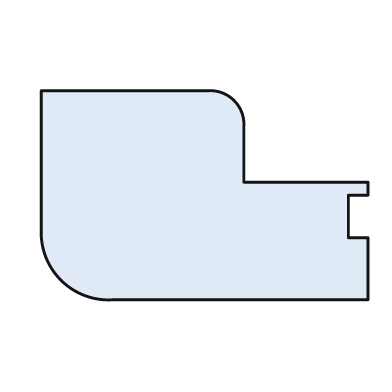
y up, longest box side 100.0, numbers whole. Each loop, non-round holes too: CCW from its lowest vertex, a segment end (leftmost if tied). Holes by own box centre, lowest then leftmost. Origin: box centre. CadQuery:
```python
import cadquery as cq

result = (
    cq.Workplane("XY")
    .moveTo(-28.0, -32.0)
    .lineTo(50.0, -32.0)
    .lineTo(50.0, -13.0)
    .lineTo(44.0, -13.0)
    .lineTo(44.0, 0.0)
    .lineTo(50.0, 0.0)
    .lineTo(50.0, 4.0)
    .lineTo(12.0, 4.0)
    .lineTo(12.0, 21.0)
    .threePointArc((9.0, 29.0), (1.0, 32.0))
    .lineTo(-50.0, 32.0)
    .lineTo(-50.0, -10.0)
    .threePointArc((-44.0, -26.0), (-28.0, -32.0))
    .close()
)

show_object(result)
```